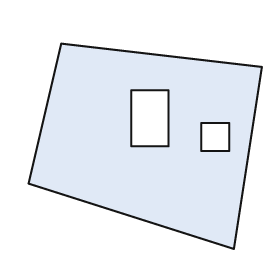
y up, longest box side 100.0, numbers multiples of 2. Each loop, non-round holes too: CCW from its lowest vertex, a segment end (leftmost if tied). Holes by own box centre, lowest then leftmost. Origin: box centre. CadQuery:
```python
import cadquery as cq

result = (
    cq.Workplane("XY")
    .moveTo(38.0, -44.0)
    .lineTo(50.0, 34.0)
    .lineTo(-36.0, 44.0)
    .lineTo(-50.0, -16.0)
    .close()
    .moveTo(24.0, -2.0)
    .lineTo(36.0, -2.0)
    .lineTo(36.0, 10.0)
    .lineTo(24.0, 10.0)
    .close()
    .moveTo(-6.0, 0.0)
    .lineTo(10.0, 0.0)
    .lineTo(10.0, 24.0)
    .lineTo(-6.0, 24.0)
    .close()
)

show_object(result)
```